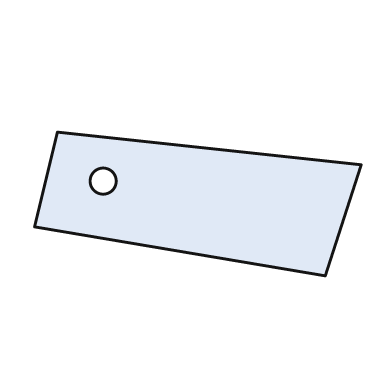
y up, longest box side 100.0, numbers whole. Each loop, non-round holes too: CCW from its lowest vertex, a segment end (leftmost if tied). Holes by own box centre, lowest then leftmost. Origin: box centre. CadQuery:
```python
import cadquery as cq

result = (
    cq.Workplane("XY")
    .moveTo(39.0, -22.0)
    .lineTo(50.0, 12.0)
    .lineTo(-43.0, 22.0)
    .lineTo(-50.0, -7.0)
    .close()
    .moveTo(-29.0, 7.0)
    .circle(4.0)
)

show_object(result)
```